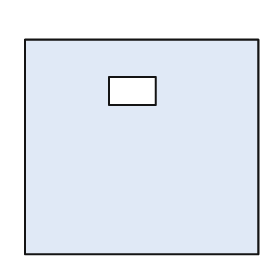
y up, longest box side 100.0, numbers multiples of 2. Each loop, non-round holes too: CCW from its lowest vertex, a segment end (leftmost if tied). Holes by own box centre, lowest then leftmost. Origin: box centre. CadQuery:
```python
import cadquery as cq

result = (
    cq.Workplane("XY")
    .moveTo(-50.0, -46.0)
    .lineTo(50.0, -46.0)
    .lineTo(50.0, 46.0)
    .lineTo(-50.0, 46.0)
    .close()
    .moveTo(-14.0, 18.0)
    .lineTo(6.0, 18.0)
    .lineTo(6.0, 30.0)
    .lineTo(-14.0, 30.0)
    .close()
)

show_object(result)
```